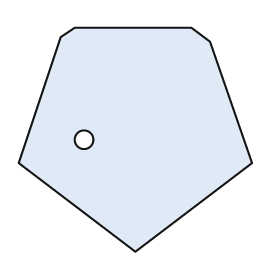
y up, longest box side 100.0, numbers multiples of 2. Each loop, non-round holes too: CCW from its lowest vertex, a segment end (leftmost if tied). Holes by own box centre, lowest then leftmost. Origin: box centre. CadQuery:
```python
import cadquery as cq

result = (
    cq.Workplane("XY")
    .moveTo(0.0, -48.0)
    .lineTo(50.0, -10.0)
    .lineTo(32.0, 42.0)
    .lineTo(24.0, 48.0)
    .lineTo(-26.0, 48.0)
    .lineTo(-32.0, 44.0)
    .lineTo(-50.0, -10.0)
    .close()
    .moveTo(-22.0, 0.0)
    .circle(4.0)
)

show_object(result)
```